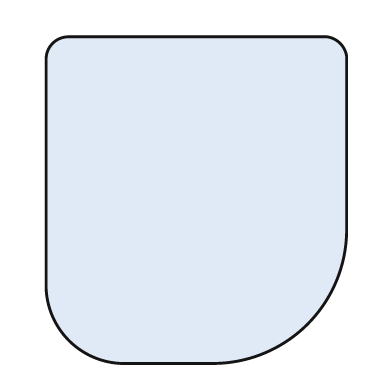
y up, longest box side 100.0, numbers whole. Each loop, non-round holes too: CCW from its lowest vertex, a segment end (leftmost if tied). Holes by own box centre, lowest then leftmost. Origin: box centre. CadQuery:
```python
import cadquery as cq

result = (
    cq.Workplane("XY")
    .moveTo(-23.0, -50.0)
    .lineTo(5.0, -50.0)
    .threePointArc((34.0, -38.0), (46.0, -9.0))
    .lineTo(46.0, 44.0)
    .threePointArc((44.0, 48.0), (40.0, 50.0))
    .lineTo(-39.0, 50.0)
    .threePointArc((-44.0, 48.0), (-46.0, 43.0))
    .lineTo(-46.0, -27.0)
    .threePointArc((-39.0, -43.0), (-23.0, -50.0))
    .close()
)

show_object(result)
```